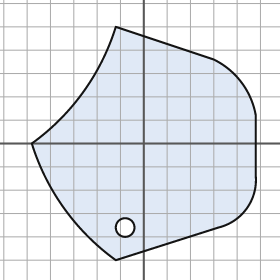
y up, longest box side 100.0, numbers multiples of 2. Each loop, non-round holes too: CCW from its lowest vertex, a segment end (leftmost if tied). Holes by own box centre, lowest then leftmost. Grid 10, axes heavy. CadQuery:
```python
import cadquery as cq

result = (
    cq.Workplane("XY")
    .moveTo(-12.0, -50.0)
    .lineTo(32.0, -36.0)
    .threePointArc((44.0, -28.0), (48.0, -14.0))
    .lineTo(48.0, 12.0)
    .threePointArc((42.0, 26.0), (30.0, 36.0))
    .lineTo(-12.0, 50.0)
    .threePointArc((-26.0, 22.0), (-48.0, 0.0))
    .threePointArc((-34.0, -28.0), (-12.0, -50.0))
    .close()
    .moveTo(-8.0, -36.0)
    .circle(4.0)
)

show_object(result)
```